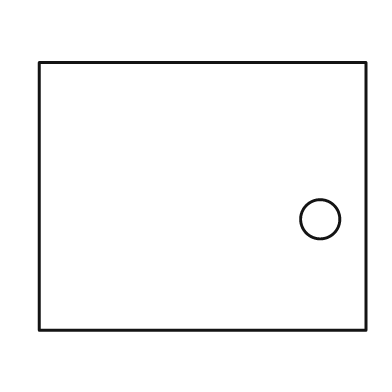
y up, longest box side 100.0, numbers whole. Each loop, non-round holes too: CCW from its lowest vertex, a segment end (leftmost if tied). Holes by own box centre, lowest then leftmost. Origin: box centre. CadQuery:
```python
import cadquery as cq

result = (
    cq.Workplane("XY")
    .moveTo(-50.0, -41.0)
    .lineTo(50.0, -41.0)
    .lineTo(50.0, 41.0)
    .lineTo(-50.0, 41.0)
    .close()
    .moveTo(36.0, -7.0)
    .circle(6.0)
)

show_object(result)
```